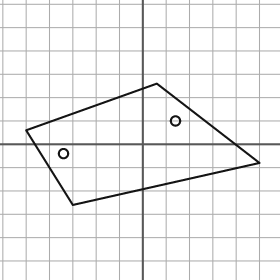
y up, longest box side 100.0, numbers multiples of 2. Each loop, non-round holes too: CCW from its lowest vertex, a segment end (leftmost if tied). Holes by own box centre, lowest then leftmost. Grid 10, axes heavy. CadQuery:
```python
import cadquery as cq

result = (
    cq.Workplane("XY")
    .moveTo(-30.0, -26.0)
    .lineTo(50.0, -8.0)
    .lineTo(6.0, 26.0)
    .lineTo(-50.0, 6.0)
    .close()
    .moveTo(-34.0, -4.0)
    .circle(2.0)
    .moveTo(14.0, 10.0)
    .circle(2.0)
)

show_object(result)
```